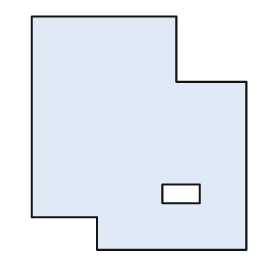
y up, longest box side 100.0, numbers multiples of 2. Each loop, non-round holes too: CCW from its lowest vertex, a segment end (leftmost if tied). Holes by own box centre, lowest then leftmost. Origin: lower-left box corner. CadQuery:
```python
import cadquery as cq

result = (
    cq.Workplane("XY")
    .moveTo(28.0, 0.0)
    .lineTo(92.0, 0.0)
    .lineTo(92.0, 72.0)
    .lineTo(62.0, 72.0)
    .lineTo(62.0, 100.0)
    .lineTo(0.0, 100.0)
    .lineTo(0.0, 14.0)
    .lineTo(28.0, 14.0)
    .close()
    .moveTo(56.0, 20.0)
    .lineTo(72.0, 20.0)
    .lineTo(72.0, 28.0)
    .lineTo(56.0, 28.0)
    .close()
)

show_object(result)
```